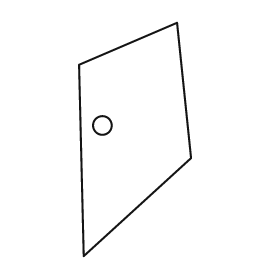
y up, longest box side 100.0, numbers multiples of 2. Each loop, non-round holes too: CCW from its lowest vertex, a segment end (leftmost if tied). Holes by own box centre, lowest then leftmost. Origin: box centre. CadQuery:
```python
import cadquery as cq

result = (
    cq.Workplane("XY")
    .moveTo(-22.0, -50.0)
    .lineTo(24.0, -8.0)
    .lineTo(18.0, 50.0)
    .lineTo(-24.0, 32.0)
    .close()
    .moveTo(-14.0, 6.0)
    .circle(4.0)
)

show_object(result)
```